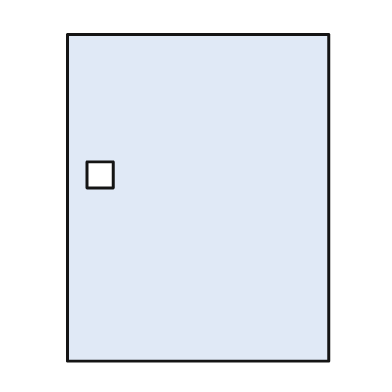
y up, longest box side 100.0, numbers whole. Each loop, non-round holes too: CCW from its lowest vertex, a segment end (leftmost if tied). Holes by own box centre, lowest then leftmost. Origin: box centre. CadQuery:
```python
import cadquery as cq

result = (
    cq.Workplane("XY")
    .moveTo(-40.0, -50.0)
    .lineTo(40.0, -50.0)
    .lineTo(40.0, 50.0)
    .lineTo(-40.0, 50.0)
    .close()
    .moveTo(-34.0, 3.0)
    .lineTo(-26.0, 3.0)
    .lineTo(-26.0, 11.0)
    .lineTo(-34.0, 11.0)
    .close()
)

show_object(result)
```